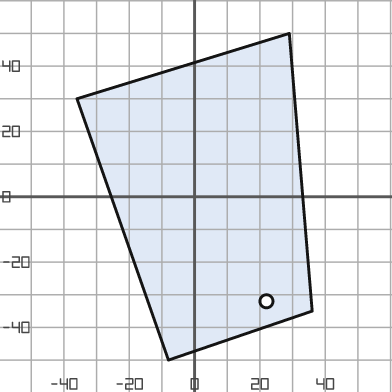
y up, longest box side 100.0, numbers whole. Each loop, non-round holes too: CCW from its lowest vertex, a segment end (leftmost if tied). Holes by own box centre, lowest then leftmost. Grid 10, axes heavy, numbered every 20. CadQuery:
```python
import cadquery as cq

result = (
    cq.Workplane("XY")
    .moveTo(-8.0, -50.0)
    .lineTo(36.0, -35.0)
    .lineTo(29.0, 50.0)
    .lineTo(-36.0, 30.0)
    .close()
    .moveTo(22.0, -32.0)
    .circle(2.0)
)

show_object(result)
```